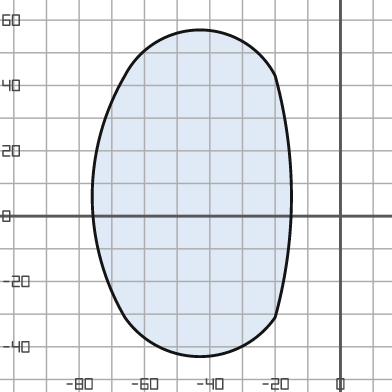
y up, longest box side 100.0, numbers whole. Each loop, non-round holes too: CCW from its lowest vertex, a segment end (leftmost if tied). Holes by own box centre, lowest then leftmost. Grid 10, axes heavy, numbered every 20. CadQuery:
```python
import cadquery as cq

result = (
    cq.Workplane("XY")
    .moveTo(-66.0, -31.0)
    .threePointArc((-43.0, -43.0), (-20.0, -31.0))
    .threePointArc((-15.0, 6.0), (-20.0, 43.0))
    .threePointArc((-43.0, 57.0), (-66.0, 43.0))
    .threePointArc((-76.0, 6.0), (-66.0, -31.0))
    .close()
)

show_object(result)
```